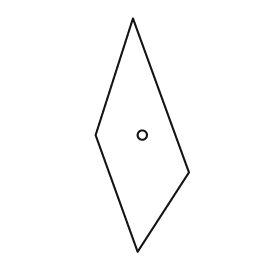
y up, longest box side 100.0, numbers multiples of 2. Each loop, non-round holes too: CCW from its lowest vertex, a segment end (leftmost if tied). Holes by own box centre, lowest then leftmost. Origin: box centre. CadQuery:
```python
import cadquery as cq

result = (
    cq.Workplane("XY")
    .moveTo(-2.0, -50.0)
    .lineTo(20.0, -16.0)
    .lineTo(-4.0, 50.0)
    .lineTo(-20.0, 0.0)
    .close()
    .moveTo(0.0, 0.0)
    .circle(2.0)
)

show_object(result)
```